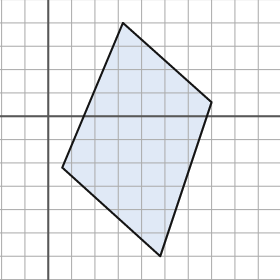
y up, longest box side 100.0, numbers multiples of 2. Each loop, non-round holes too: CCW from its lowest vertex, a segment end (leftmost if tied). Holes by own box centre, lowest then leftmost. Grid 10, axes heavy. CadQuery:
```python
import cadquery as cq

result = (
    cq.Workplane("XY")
    .moveTo(48.0, -60.0)
    .lineTo(70.0, 6.0)
    .lineTo(32.0, 40.0)
    .lineTo(6.0, -22.0)
    .close()
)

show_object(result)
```